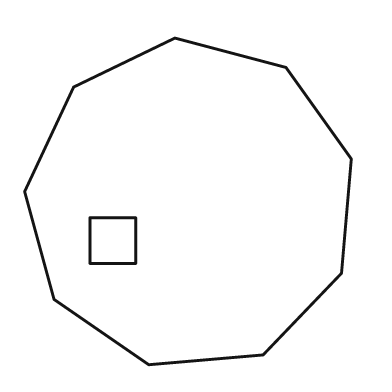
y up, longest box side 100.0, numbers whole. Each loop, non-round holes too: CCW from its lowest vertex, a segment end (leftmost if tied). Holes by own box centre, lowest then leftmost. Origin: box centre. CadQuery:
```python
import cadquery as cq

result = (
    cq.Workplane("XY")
    .moveTo(-12.0, -50.0)
    .lineTo(23.0, -47.0)
    .lineTo(47.0, -22.0)
    .lineTo(50.0, 13.0)
    .lineTo(30.0, 41.0)
    .lineTo(-4.0, 50.0)
    .lineTo(-35.0, 35.0)
    .lineTo(-50.0, 3.0)
    .lineTo(-41.0, -30.0)
    .close()
    .moveTo(-30.0, -19.0)
    .lineTo(-16.0, -19.0)
    .lineTo(-16.0, -5.0)
    .lineTo(-30.0, -5.0)
    .close()
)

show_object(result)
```